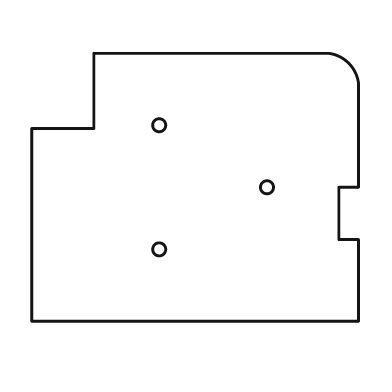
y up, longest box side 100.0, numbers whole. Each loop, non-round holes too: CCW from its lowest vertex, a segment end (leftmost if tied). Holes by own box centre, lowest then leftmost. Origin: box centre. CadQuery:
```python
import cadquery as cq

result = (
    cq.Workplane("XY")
    .moveTo(-50.0, -41.0)
    .lineTo(50.0, -41.0)
    .lineTo(50.0, -16.0)
    .lineTo(44.0, -16.0)
    .lineTo(44.0, 0.0)
    .lineTo(50.0, 0.0)
    .lineTo(50.0, 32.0)
    .threePointArc((47.0, 38.0), (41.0, 41.0))
    .lineTo(-31.0, 41.0)
    .lineTo(-31.0, 18.0)
    .lineTo(-50.0, 18.0)
    .close()
    .moveTo(-11.0, -19.0)
    .circle(2.0)
    .moveTo(22.0, 0.0)
    .circle(2.0)
    .moveTo(-11.0, 19.0)
    .circle(2.0)
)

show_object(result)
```